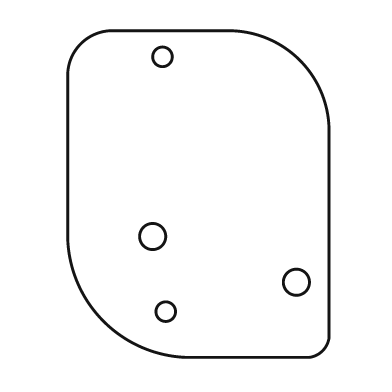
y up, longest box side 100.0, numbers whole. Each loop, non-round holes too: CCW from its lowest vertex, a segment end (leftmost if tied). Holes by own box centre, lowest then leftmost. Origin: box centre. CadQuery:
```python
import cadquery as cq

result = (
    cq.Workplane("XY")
    .moveTo(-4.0, -50.0)
    .lineTo(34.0, -50.0)
    .threePointArc((38.0, -48.0), (40.0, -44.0))
    .lineTo(40.0, 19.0)
    .threePointArc((31.0, 41.0), (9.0, 50.0))
    .lineTo(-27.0, 50.0)
    .threePointArc((-36.0, 46.0), (-40.0, 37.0))
    .lineTo(-40.0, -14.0)
    .threePointArc((-29.0, -39.0), (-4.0, -50.0))
    .close()
    .moveTo(-10.0, -36.0)
    .circle(3.0)
    .moveTo(30.0, -27.0)
    .circle(4.0)
    .moveTo(-14.0, -13.0)
    .circle(4.0)
    .moveTo(-11.0, 42.0)
    .circle(3.0)
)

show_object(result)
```